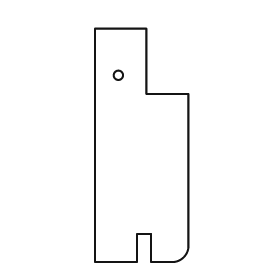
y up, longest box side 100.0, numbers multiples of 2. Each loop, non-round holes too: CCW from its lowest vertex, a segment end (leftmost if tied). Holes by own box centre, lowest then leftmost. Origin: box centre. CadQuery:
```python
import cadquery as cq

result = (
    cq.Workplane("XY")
    .moveTo(-20.0, -50.0)
    .lineTo(-2.0, -50.0)
    .lineTo(-2.0, -38.0)
    .lineTo(4.0, -38.0)
    .lineTo(4.0, -50.0)
    .lineTo(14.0, -50.0)
    .threePointArc((18.0, -48.0), (20.0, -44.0))
    .lineTo(20.0, 22.0)
    .lineTo(2.0, 22.0)
    .lineTo(2.0, 50.0)
    .lineTo(-20.0, 50.0)
    .close()
    .moveTo(-10.0, 30.0)
    .circle(2.0)
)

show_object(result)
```